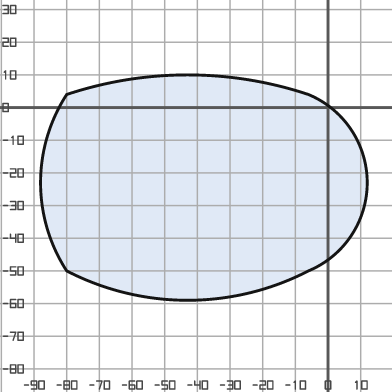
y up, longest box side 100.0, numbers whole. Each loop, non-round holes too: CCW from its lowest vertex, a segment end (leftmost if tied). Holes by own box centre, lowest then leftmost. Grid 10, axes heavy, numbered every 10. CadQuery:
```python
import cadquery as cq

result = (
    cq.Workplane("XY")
    .moveTo(-80.0, -50.0)
    .threePointArc((-43.0, -59.0), (-6.0, -50.0))
    .threePointArc((12.0, -23.0), (-6.0, 4.0))
    .threePointArc((-43.0, 10.0), (-80.0, 4.0))
    .threePointArc((-88.0, -23.0), (-80.0, -50.0))
    .close()
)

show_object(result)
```